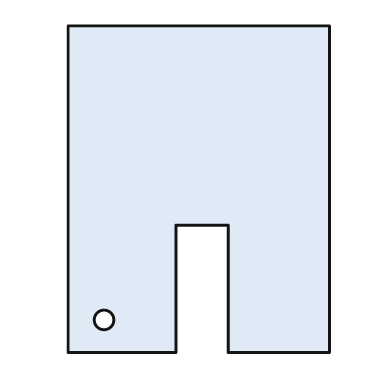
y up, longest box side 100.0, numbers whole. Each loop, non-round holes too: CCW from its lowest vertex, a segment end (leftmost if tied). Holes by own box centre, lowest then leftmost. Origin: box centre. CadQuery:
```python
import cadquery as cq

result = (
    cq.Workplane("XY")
    .moveTo(-40.0, -50.0)
    .lineTo(-7.0, -50.0)
    .lineTo(-7.0, -11.0)
    .lineTo(9.0, -11.0)
    .lineTo(9.0, -50.0)
    .lineTo(40.0, -50.0)
    .lineTo(40.0, 50.0)
    .lineTo(-40.0, 50.0)
    .close()
    .moveTo(-29.0, -40.0)
    .circle(3.0)
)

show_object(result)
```